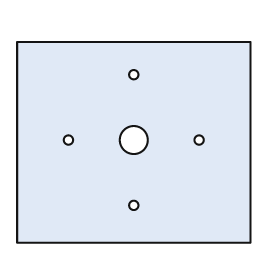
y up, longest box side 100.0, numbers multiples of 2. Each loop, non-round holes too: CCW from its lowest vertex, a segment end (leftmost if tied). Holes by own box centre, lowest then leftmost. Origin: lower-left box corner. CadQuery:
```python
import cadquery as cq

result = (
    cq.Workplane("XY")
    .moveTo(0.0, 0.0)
    .lineTo(100.0, 0.0)
    .lineTo(100.0, 86.0)
    .lineTo(0.0, 86.0)
    .close()
    .moveTo(50.0, 16.0)
    .circle(2.0)
    .moveTo(22.0, 44.0)
    .circle(2.0)
    .moveTo(50.0, 44.0)
    .circle(6.0)
    .moveTo(78.0, 44.0)
    .circle(2.0)
    .moveTo(50.0, 72.0)
    .circle(2.0)
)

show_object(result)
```